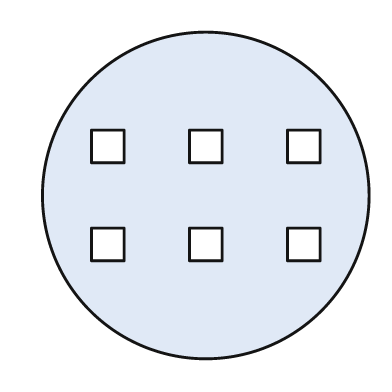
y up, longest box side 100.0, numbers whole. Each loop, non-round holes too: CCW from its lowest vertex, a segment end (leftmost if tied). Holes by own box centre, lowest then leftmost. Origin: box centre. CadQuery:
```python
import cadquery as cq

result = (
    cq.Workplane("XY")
    .moveTo(0.0, 0.0)
    .circle(50.0)
    .moveTo(-35.0, -20.0)
    .lineTo(-25.0, -20.0)
    .lineTo(-25.0, -10.0)
    .lineTo(-35.0, -10.0)
    .close()
    .moveTo(-5.0, -20.0)
    .lineTo(5.0, -20.0)
    .lineTo(5.0, -10.0)
    .lineTo(-5.0, -10.0)
    .close()
    .moveTo(25.0, -20.0)
    .lineTo(35.0, -20.0)
    .lineTo(35.0, -10.0)
    .lineTo(25.0, -10.0)
    .close()
    .moveTo(-35.0, 10.0)
    .lineTo(-25.0, 10.0)
    .lineTo(-25.0, 20.0)
    .lineTo(-35.0, 20.0)
    .close()
    .moveTo(-5.0, 10.0)
    .lineTo(5.0, 10.0)
    .lineTo(5.0, 20.0)
    .lineTo(-5.0, 20.0)
    .close()
    .moveTo(25.0, 10.0)
    .lineTo(35.0, 10.0)
    .lineTo(35.0, 20.0)
    .lineTo(25.0, 20.0)
    .close()
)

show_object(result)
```